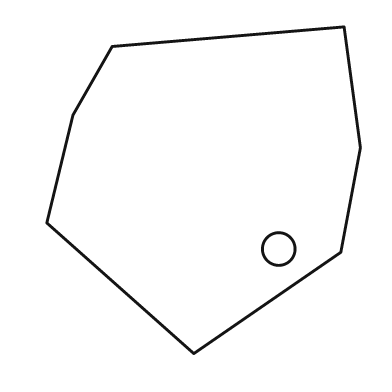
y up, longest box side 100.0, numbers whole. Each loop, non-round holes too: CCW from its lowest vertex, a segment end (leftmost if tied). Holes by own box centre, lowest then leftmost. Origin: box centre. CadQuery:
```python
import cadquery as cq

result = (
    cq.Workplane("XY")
    .moveTo(-3.0, -50.0)
    .lineTo(42.0, -19.0)
    .lineTo(48.0, 13.0)
    .lineTo(43.0, 50.0)
    .lineTo(-28.0, 44.0)
    .lineTo(-40.0, 23.0)
    .lineTo(-48.0, -10.0)
    .close()
    .moveTo(23.0, -18.0)
    .circle(5.0)
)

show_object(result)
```